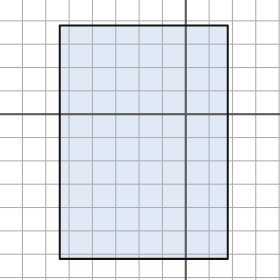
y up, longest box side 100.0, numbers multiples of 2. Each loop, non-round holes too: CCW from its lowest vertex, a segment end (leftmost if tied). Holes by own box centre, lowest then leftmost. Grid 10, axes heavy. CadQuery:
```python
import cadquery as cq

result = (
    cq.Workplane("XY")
    .moveTo(-54.0, -62.0)
    .lineTo(18.0, -62.0)
    .lineTo(18.0, 38.0)
    .lineTo(-54.0, 38.0)
    .close()
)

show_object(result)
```